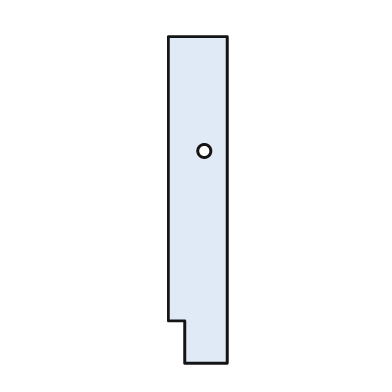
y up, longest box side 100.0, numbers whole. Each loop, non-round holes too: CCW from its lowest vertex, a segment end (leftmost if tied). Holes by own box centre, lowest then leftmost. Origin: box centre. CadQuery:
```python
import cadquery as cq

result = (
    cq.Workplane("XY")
    .moveTo(-4.0, -50.0)
    .lineTo(9.0, -50.0)
    .lineTo(9.0, 50.0)
    .lineTo(-9.0, 50.0)
    .lineTo(-9.0, -37.0)
    .lineTo(-4.0, -37.0)
    .close()
    .moveTo(2.0, 15.0)
    .circle(2.0)
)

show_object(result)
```